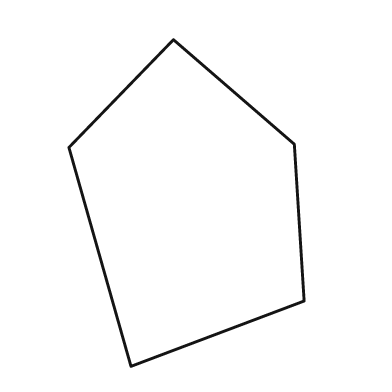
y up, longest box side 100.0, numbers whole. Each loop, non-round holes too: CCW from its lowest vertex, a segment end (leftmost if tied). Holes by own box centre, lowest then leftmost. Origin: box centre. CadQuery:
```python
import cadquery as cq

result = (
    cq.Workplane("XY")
    .moveTo(-17.0, -50.0)
    .lineTo(36.0, -30.0)
    .lineTo(33.0, 18.0)
    .lineTo(-4.0, 50.0)
    .lineTo(-36.0, 17.0)
    .close()
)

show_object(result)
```